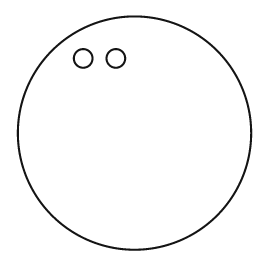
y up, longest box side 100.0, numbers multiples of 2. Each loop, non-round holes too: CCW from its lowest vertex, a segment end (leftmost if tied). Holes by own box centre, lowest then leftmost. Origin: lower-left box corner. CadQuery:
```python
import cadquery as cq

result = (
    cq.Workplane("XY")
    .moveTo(50.0, 50.0)
    .circle(50.0)
    .moveTo(28.0, 82.0)
    .circle(4.0)
    .moveTo(42.0, 82.0)
    .circle(4.0)
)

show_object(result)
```